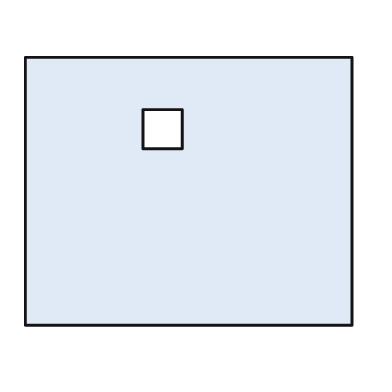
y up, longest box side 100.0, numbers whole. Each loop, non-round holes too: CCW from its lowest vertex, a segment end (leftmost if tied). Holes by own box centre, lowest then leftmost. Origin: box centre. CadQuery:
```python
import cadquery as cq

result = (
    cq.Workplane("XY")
    .moveTo(-50.0, -41.0)
    .lineTo(50.0, -41.0)
    .lineTo(50.0, 41.0)
    .lineTo(-50.0, 41.0)
    .close()
    .moveTo(-14.0, 13.0)
    .lineTo(-2.0, 13.0)
    .lineTo(-2.0, 25.0)
    .lineTo(-14.0, 25.0)
    .close()
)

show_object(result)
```